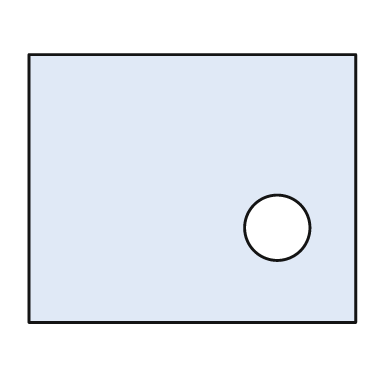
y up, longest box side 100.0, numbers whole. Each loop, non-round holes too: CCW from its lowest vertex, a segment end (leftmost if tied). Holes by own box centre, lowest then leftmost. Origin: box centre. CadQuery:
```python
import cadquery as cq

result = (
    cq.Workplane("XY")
    .moveTo(-50.0, -41.0)
    .lineTo(50.0, -41.0)
    .lineTo(50.0, 41.0)
    .lineTo(-50.0, 41.0)
    .close()
    .moveTo(26.0, -12.0)
    .circle(10.0)
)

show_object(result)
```